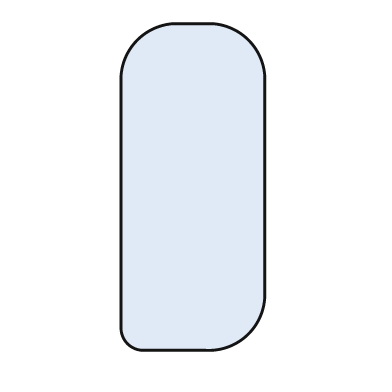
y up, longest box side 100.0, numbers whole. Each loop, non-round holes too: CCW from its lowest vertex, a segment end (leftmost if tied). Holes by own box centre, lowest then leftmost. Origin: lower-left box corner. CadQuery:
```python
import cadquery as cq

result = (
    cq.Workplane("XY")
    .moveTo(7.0, 0.0)
    .lineTo(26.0, 0.0)
    .threePointArc((39.0, 5.0), (44.0, 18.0))
    .lineTo(44.0, 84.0)
    .threePointArc((39.0, 95.0), (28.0, 100.0))
    .lineTo(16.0, 100.0)
    .threePointArc((5.0, 95.0), (0.0, 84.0))
    .lineTo(0.0, 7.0)
    .threePointArc((2.0, 2.0), (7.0, 0.0))
    .close()
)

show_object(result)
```